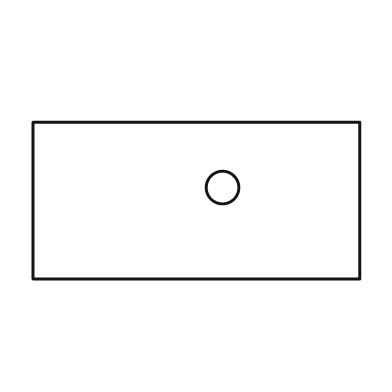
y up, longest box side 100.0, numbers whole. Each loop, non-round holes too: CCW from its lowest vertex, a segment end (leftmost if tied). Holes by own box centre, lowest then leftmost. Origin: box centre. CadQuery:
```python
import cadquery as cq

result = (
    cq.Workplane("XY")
    .moveTo(-50.0, -24.0)
    .lineTo(50.0, -24.0)
    .lineTo(50.0, 24.0)
    .lineTo(-50.0, 24.0)
    .close()
    .moveTo(8.0, 4.0)
    .circle(5.0)
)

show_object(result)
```